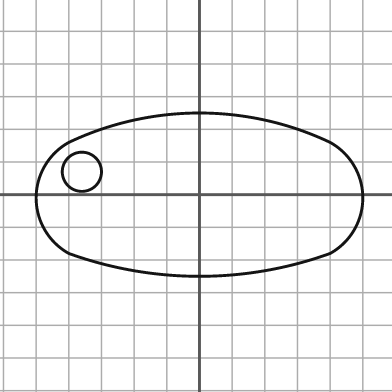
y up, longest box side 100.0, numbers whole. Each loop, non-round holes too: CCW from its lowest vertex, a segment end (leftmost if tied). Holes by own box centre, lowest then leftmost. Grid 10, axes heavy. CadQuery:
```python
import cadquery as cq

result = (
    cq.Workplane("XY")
    .moveTo(-40.0, -18.0)
    .threePointArc((0.0, -25.0), (40.0, -18.0))
    .threePointArc((50.0, -1.0), (40.0, 16.0))
    .threePointArc((0.0, 25.0), (-40.0, 16.0))
    .threePointArc((-50.0, -1.0), (-40.0, -18.0))
    .close()
    .moveTo(-36.0, 7.0)
    .circle(6.0)
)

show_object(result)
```